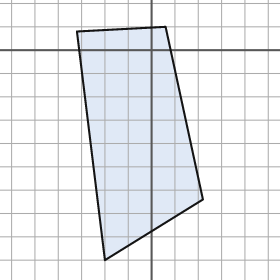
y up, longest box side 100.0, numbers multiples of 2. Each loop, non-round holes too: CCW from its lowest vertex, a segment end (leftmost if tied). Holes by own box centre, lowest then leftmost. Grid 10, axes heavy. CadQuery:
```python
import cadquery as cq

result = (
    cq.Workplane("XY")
    .moveTo(-20.0, -90.0)
    .lineTo(22.0, -64.0)
    .lineTo(6.0, 10.0)
    .lineTo(-32.0, 8.0)
    .close()
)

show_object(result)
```